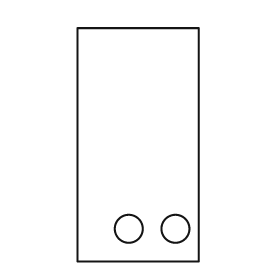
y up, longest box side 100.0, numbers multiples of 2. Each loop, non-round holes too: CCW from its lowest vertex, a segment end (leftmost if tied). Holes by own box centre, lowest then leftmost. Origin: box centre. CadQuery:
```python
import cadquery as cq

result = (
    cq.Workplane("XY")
    .moveTo(-26.0, -50.0)
    .lineTo(26.0, -50.0)
    .lineTo(26.0, 50.0)
    .lineTo(-26.0, 50.0)
    .close()
    .moveTo(-4.0, -36.0)
    .circle(6.0)
    .moveTo(16.0, -36.0)
    .circle(6.0)
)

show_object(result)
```